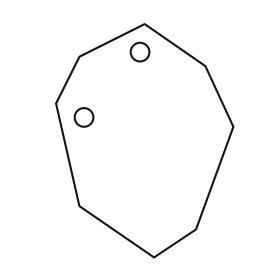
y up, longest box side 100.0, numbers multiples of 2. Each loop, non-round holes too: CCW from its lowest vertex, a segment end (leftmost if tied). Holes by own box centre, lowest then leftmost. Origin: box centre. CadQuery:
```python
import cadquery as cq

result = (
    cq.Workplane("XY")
    .moveTo(4.0, -50.0)
    .lineTo(22.0, -38.0)
    .lineTo(38.0, 6.0)
    .lineTo(26.0, 32.0)
    .lineTo(0.0, 50.0)
    .lineTo(-28.0, 36.0)
    .lineTo(-38.0, 16.0)
    .lineTo(-28.0, -28.0)
    .close()
    .moveTo(-26.0, 10.0)
    .circle(4.0)
    .moveTo(-2.0, 38.0)
    .circle(4.0)
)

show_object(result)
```